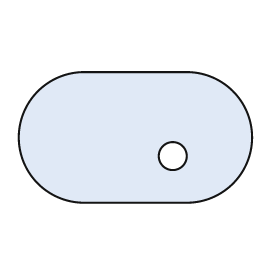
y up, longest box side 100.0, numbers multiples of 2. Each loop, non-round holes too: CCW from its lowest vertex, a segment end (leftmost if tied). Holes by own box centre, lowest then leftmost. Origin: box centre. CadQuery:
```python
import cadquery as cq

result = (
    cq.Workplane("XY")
    .moveTo(-22.0, -28.0)
    .lineTo(22.0, -28.0)
    .threePointArc((50.0, 0.0), (22.0, 28.0))
    .lineTo(-22.0, 28.0)
    .threePointArc((-50.0, 0.0), (-22.0, -28.0))
    .close()
    .moveTo(16.0, -8.0)
    .circle(6.0)
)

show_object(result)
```